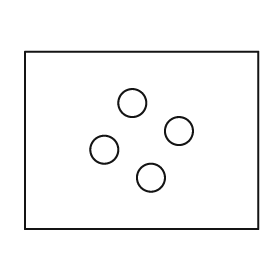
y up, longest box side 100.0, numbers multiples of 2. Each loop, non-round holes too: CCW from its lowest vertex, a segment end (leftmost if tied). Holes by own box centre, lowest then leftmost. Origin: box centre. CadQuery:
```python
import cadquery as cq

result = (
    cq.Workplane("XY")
    .moveTo(-50.0, -38.0)
    .lineTo(50.0, -38.0)
    .lineTo(50.0, 38.0)
    .lineTo(-50.0, 38.0)
    .close()
    .moveTo(4.0, -16.0)
    .circle(6.0)
    .moveTo(-16.0, -4.0)
    .circle(6.0)
    .moveTo(16.0, 4.0)
    .circle(6.0)
    .moveTo(-4.0, 16.0)
    .circle(6.0)
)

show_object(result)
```